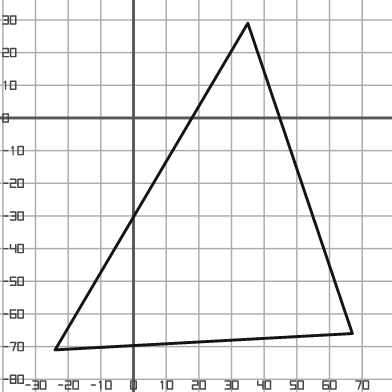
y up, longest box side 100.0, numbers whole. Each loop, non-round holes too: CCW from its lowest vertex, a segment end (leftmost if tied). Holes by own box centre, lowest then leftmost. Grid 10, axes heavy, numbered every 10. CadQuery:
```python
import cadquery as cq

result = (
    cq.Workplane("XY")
    .moveTo(-24.0, -71.0)
    .lineTo(67.0, -66.0)
    .lineTo(35.0, 29.0)
    .close()
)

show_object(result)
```